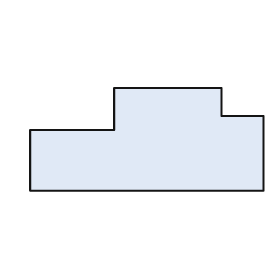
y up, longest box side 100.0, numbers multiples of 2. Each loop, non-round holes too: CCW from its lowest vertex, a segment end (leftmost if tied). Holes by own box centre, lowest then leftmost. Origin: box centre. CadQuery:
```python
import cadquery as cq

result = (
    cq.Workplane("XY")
    .moveTo(-50.0, -22.0)
    .lineTo(50.0, -22.0)
    .lineTo(50.0, 10.0)
    .lineTo(32.0, 10.0)
    .lineTo(32.0, 22.0)
    .lineTo(-14.0, 22.0)
    .lineTo(-14.0, 4.0)
    .lineTo(-50.0, 4.0)
    .close()
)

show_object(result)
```